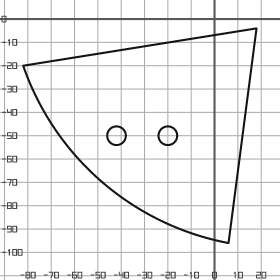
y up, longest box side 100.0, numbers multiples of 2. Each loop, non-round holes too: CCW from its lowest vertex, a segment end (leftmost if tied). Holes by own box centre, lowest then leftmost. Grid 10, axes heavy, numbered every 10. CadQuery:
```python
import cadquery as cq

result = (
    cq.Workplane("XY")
    .moveTo(6.0, -96.0)
    .lineTo(18.0, -4.0)
    .lineTo(-82.0, -20.0)
    .threePointArc((-48.0, -70.0), (6.0, -96.0))
    .close()
    .moveTo(-42.0, -50.0)
    .circle(4.0)
    .moveTo(-20.0, -50.0)
    .circle(4.0)
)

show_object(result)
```